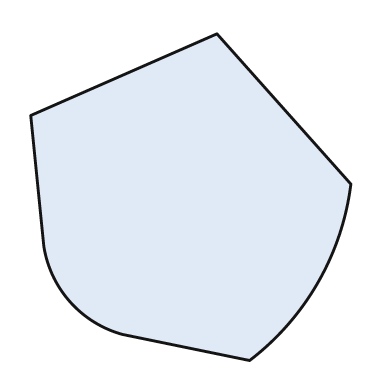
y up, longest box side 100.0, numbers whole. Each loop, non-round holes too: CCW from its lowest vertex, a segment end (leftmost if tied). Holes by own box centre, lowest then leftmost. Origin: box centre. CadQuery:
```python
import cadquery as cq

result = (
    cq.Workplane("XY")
    .moveTo(18.0, -50.0)
    .threePointArc((39.0, -26.0), (49.0, 4.0))
    .lineTo(8.0, 50.0)
    .lineTo(-49.0, 25.0)
    .lineTo(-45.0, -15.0)
    .threePointArc((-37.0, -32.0), (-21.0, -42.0))
    .close()
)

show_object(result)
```